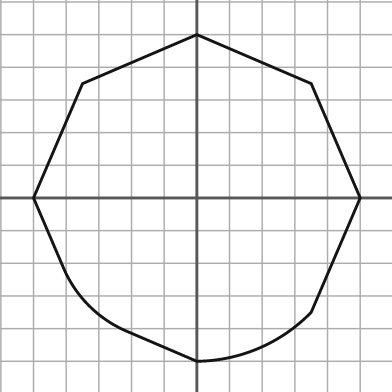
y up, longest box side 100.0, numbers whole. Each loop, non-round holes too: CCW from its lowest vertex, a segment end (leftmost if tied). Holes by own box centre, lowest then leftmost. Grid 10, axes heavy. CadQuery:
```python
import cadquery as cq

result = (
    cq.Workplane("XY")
    .moveTo(0.0, -50.0)
    .threePointArc((19.0, -46.0), (35.0, -35.0))
    .lineTo(50.0, 0.0)
    .lineTo(35.0, 35.0)
    .lineTo(0.0, 50.0)
    .lineTo(-35.0, 35.0)
    .lineTo(-50.0, 0.0)
    .lineTo(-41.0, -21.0)
    .threePointArc((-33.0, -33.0), (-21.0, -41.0))
    .close()
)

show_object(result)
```